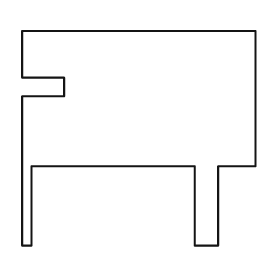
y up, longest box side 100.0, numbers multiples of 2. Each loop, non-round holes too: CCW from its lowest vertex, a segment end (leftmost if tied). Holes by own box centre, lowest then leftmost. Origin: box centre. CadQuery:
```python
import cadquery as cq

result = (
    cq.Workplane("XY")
    .moveTo(-50.0, -46.0)
    .lineTo(-46.0, -46.0)
    .lineTo(-46.0, -12.0)
    .lineTo(24.0, -12.0)
    .lineTo(24.0, -46.0)
    .lineTo(34.0, -46.0)
    .lineTo(34.0, -12.0)
    .lineTo(50.0, -12.0)
    .lineTo(50.0, 46.0)
    .lineTo(-50.0, 46.0)
    .lineTo(-50.0, 26.0)
    .lineTo(-32.0, 26.0)
    .lineTo(-32.0, 18.0)
    .lineTo(-50.0, 18.0)
    .close()
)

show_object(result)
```